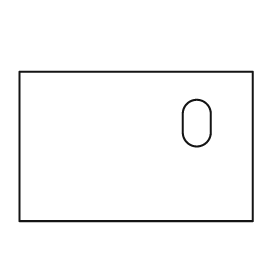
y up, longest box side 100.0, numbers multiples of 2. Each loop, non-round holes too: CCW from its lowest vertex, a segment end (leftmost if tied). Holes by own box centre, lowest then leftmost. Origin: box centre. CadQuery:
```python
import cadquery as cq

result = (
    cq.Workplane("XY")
    .moveTo(-50.0, -32.0)
    .lineTo(50.0, -32.0)
    .lineTo(50.0, 32.0)
    .lineTo(-50.0, 32.0)
    .close()
    .moveTo(20.0, 6.0)
    .threePointArc((26.0, 0.0), (32.0, 6.0))
    .lineTo(32.0, 14.0)
    .threePointArc((26.0, 20.0), (20.0, 14.0))
    .close()
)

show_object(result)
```